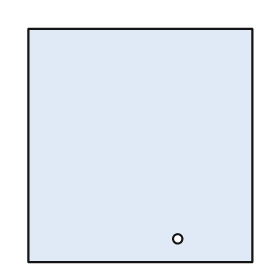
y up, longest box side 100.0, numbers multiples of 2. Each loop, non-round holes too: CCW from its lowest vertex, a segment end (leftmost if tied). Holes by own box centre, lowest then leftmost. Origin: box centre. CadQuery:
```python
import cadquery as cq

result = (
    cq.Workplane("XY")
    .moveTo(-48.0, -50.0)
    .lineTo(48.0, -50.0)
    .lineTo(48.0, 50.0)
    .lineTo(-48.0, 50.0)
    .close()
    .moveTo(16.0, -40.0)
    .circle(2.0)
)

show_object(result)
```